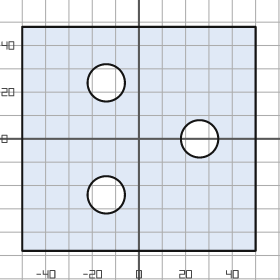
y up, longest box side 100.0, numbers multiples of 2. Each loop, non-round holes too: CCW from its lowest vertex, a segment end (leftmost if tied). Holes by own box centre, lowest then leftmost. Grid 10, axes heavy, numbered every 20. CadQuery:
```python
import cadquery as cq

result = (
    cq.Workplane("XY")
    .moveTo(-50.0, -48.0)
    .lineTo(50.0, -48.0)
    .lineTo(50.0, 48.0)
    .lineTo(-50.0, 48.0)
    .close()
    .moveTo(-14.0, -24.0)
    .circle(8.0)
    .moveTo(26.0, 0.0)
    .circle(8.0)
    .moveTo(-14.0, 24.0)
    .circle(8.0)
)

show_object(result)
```